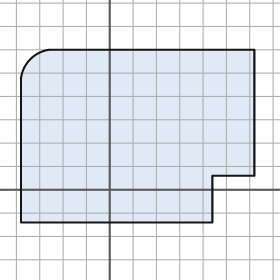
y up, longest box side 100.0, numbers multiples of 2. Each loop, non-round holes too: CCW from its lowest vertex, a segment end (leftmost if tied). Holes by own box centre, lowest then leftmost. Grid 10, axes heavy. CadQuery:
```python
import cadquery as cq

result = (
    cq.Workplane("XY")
    .moveTo(-38.0, -14.0)
    .lineTo(44.0, -14.0)
    .lineTo(44.0, 6.0)
    .lineTo(62.0, 6.0)
    .lineTo(62.0, 60.0)
    .lineTo(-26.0, 60.0)
    .threePointArc((-34.0, 56.0), (-38.0, 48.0))
    .close()
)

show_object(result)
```